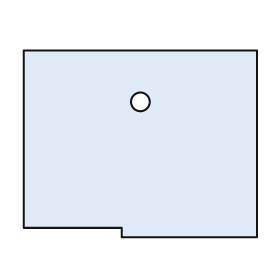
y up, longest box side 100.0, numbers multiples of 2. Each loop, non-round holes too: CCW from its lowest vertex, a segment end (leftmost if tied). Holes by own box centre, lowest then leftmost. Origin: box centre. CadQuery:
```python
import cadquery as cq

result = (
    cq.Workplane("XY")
    .moveTo(-8.0, -40.0)
    .lineTo(50.0, -40.0)
    .lineTo(50.0, 40.0)
    .lineTo(-50.0, 40.0)
    .lineTo(-50.0, -36.0)
    .lineTo(-8.0, -36.0)
    .close()
    .moveTo(0.0, 18.0)
    .circle(4.0)
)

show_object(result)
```